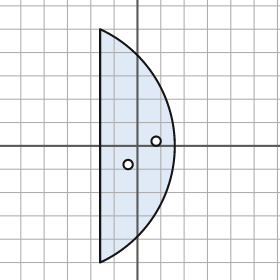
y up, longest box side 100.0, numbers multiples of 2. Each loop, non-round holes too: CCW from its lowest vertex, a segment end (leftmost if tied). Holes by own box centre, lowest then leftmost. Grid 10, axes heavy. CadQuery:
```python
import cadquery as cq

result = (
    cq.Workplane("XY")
    .moveTo(-16.0, -50.0)
    .threePointArc((16.0, 0.0), (-16.0, 50.0))
    .close()
    .moveTo(-4.0, -8.0)
    .circle(2.0)
    .moveTo(8.0, 2.0)
    .circle(2.0)
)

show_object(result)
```